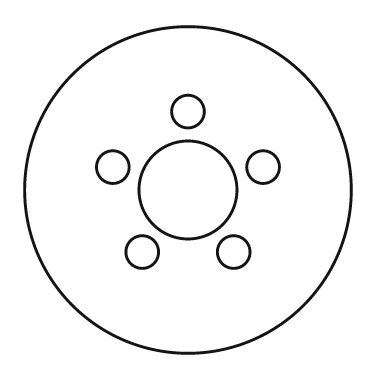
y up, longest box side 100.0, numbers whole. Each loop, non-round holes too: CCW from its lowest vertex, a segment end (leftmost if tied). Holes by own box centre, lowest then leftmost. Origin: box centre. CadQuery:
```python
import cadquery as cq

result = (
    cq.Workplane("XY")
    .moveTo(0.0, 0.0)
    .circle(50.0)
    .moveTo(-14.0, -19.0)
    .circle(5.0)
    .moveTo(14.0, -19.0)
    .circle(5.0)
    .moveTo(0.0, 0.0)
    .circle(15.0)
    .moveTo(-23.0, 7.0)
    .circle(5.0)
    .moveTo(23.0, 7.0)
    .circle(5.0)
    .moveTo(0.0, 24.0)
    .circle(5.0)
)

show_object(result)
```